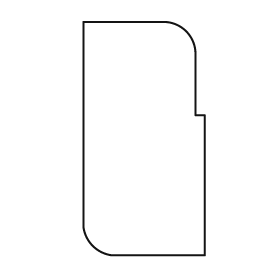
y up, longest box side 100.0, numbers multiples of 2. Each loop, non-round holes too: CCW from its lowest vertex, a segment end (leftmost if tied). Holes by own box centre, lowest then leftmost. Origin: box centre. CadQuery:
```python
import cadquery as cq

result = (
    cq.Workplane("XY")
    .moveTo(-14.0, -50.0)
    .lineTo(26.0, -50.0)
    .lineTo(26.0, 10.0)
    .lineTo(22.0, 10.0)
    .lineTo(22.0, 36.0)
    .threePointArc((18.0, 46.0), (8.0, 50.0))
    .lineTo(-26.0, 50.0)
    .lineTo(-26.0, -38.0)
    .threePointArc((-22.0, -46.0), (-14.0, -50.0))
    .close()
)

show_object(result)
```